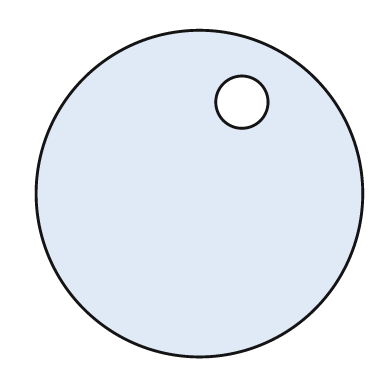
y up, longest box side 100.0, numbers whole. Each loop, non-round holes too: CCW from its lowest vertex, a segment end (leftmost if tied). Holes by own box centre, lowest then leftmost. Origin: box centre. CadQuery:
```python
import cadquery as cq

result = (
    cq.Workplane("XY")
    .moveTo(0.0, 0.0)
    .circle(50.0)
    .moveTo(13.0, 28.0)
    .circle(8.0)
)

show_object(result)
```